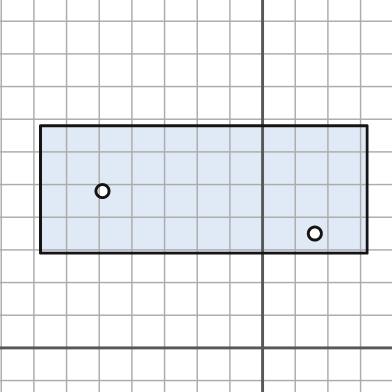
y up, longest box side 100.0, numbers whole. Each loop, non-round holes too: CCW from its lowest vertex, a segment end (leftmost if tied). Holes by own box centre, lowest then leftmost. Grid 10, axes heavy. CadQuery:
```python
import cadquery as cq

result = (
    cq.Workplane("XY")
    .moveTo(-68.0, 29.0)
    .lineTo(32.0, 29.0)
    .lineTo(32.0, 68.0)
    .lineTo(-68.0, 68.0)
    .close()
    .moveTo(16.0, 35.0)
    .circle(2.0)
    .moveTo(-49.0, 48.0)
    .circle(2.0)
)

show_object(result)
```